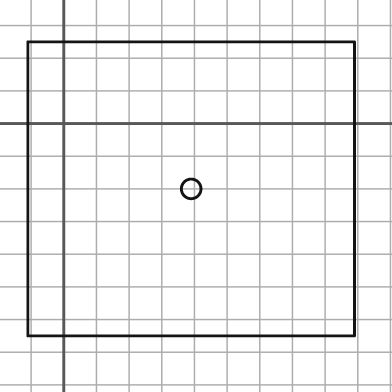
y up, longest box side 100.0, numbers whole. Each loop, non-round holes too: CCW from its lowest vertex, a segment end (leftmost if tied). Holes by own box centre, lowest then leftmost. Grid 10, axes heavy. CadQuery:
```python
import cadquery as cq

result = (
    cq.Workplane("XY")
    .moveTo(-11.0, -65.0)
    .lineTo(89.0, -65.0)
    .lineTo(89.0, 25.0)
    .lineTo(-11.0, 25.0)
    .close()
    .moveTo(39.0, -20.0)
    .circle(3.0)
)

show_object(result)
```